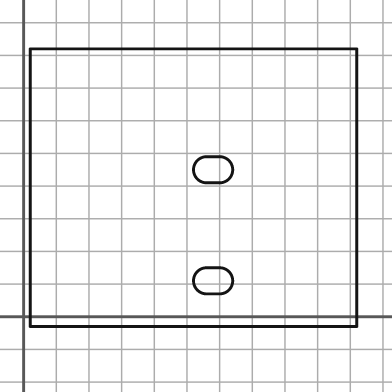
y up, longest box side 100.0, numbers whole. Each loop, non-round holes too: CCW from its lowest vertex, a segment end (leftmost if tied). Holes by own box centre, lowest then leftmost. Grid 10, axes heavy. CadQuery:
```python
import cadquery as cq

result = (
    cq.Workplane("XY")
    .moveTo(2.0, -3.0)
    .lineTo(102.0, -3.0)
    .lineTo(102.0, 82.0)
    .lineTo(2.0, 82.0)
    .close()
    .moveTo(56.0, 7.0)
    .lineTo(60.0, 7.0)
    .threePointArc((64.0, 11.0), (60.0, 15.0))
    .lineTo(56.0, 15.0)
    .threePointArc((52.0, 11.0), (56.0, 7.0))
    .close()
    .moveTo(56.0, 41.0)
    .lineTo(60.0, 41.0)
    .threePointArc((64.0, 45.0), (60.0, 49.0))
    .lineTo(56.0, 49.0)
    .threePointArc((52.0, 45.0), (56.0, 41.0))
    .close()
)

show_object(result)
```